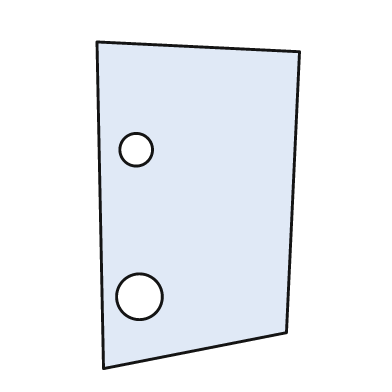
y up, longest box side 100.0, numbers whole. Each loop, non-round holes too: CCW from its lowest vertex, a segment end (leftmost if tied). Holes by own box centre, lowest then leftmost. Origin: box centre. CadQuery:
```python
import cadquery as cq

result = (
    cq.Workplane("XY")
    .moveTo(-29.0, -50.0)
    .lineTo(27.0, -39.0)
    .lineTo(31.0, 47.0)
    .lineTo(-31.0, 50.0)
    .close()
    .moveTo(-18.0, -28.0)
    .circle(7.0)
    .moveTo(-19.0, 17.0)
    .circle(5.0)
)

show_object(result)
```